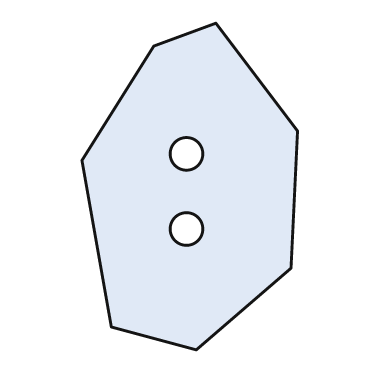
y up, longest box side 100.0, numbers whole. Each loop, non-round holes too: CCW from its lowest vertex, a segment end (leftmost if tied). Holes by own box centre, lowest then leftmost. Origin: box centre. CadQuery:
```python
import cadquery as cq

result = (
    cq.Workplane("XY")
    .moveTo(2.0, -50.0)
    .lineTo(31.0, -25.0)
    .lineTo(33.0, 17.0)
    .lineTo(8.0, 50.0)
    .lineTo(-11.0, 43.0)
    .lineTo(-33.0, 8.0)
    .lineTo(-24.0, -43.0)
    .close()
    .moveTo(-1.0, -13.0)
    .circle(5.0)
    .moveTo(-1.0, 10.0)
    .circle(5.0)
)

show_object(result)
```